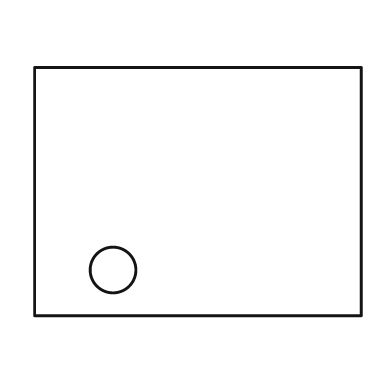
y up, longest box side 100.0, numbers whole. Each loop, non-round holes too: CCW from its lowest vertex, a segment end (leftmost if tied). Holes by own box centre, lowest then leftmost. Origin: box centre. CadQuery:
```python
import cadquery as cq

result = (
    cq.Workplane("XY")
    .moveTo(-50.0, -38.0)
    .lineTo(50.0, -38.0)
    .lineTo(50.0, 38.0)
    .lineTo(-50.0, 38.0)
    .close()
    .moveTo(-26.0, -24.0)
    .circle(7.0)
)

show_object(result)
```